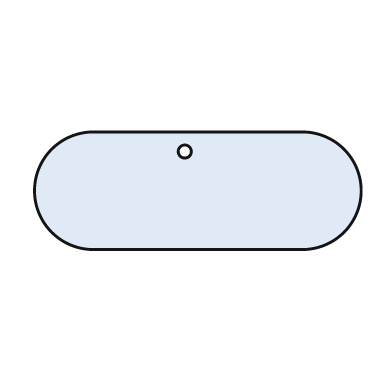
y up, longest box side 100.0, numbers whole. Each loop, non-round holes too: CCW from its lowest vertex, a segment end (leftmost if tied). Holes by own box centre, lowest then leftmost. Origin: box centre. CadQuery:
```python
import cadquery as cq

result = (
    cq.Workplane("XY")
    .moveTo(-32.0, -18.0)
    .lineTo(32.0, -18.0)
    .threePointArc((50.0, 0.0), (32.0, 18.0))
    .lineTo(-32.0, 18.0)
    .threePointArc((-50.0, 0.0), (-32.0, -18.0))
    .close()
    .moveTo(-4.0, 12.0)
    .circle(2.0)
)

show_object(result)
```